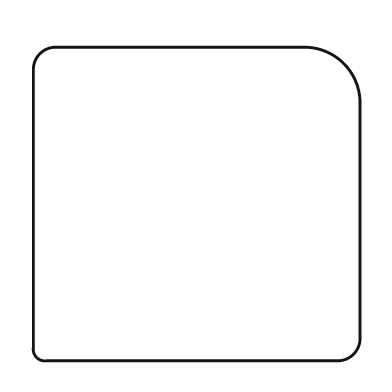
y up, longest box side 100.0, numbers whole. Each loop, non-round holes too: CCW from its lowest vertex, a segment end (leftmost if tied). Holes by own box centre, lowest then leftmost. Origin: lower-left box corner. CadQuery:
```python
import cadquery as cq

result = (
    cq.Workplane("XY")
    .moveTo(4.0, 0.0)
    .lineTo(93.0, 0.0)
    .threePointArc((98.0, 2.0), (100.0, 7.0))
    .lineTo(100.0, 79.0)
    .threePointArc((95.0, 91.0), (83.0, 96.0))
    .lineTo(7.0, 96.0)
    .threePointArc((2.0, 94.0), (0.0, 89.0))
    .lineTo(0.0, 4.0)
    .threePointArc((1.0, 1.0), (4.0, 0.0))
    .close()
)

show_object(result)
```